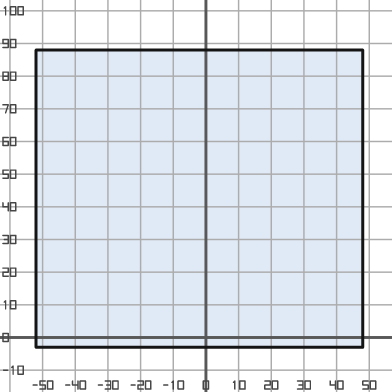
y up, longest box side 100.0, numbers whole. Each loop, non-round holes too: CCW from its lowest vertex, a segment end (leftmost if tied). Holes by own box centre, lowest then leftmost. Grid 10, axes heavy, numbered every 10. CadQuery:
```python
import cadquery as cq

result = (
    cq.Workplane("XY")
    .moveTo(-52.0, -3.0)
    .lineTo(48.0, -3.0)
    .lineTo(48.0, 88.0)
    .lineTo(-52.0, 88.0)
    .close()
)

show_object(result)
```